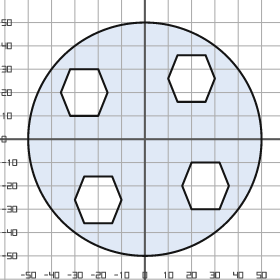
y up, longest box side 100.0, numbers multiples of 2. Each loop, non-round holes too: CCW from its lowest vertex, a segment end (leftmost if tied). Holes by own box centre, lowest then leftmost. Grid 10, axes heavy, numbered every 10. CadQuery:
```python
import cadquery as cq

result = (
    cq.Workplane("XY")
    .moveTo(0.0, 0.0)
    .circle(50.0)
    .moveTo(-26.0, -36.0)
    .lineTo(-14.0, -36.0)
    .lineTo(-10.0, -26.0)
    .lineTo(-14.0, -16.0)
    .lineTo(-26.0, -16.0)
    .lineTo(-30.0, -26.0)
    .close()
    .moveTo(20.0, -30.0)
    .lineTo(32.0, -30.0)
    .lineTo(36.0, -20.0)
    .lineTo(32.0, -10.0)
    .lineTo(20.0, -10.0)
    .lineTo(16.0, -20.0)
    .close()
    .moveTo(-32.0, 10.0)
    .lineTo(-20.0, 10.0)
    .lineTo(-16.0, 20.0)
    .lineTo(-20.0, 30.0)
    .lineTo(-32.0, 30.0)
    .lineTo(-36.0, 20.0)
    .close()
    .moveTo(14.0, 16.0)
    .lineTo(26.0, 16.0)
    .lineTo(30.0, 26.0)
    .lineTo(26.0, 36.0)
    .lineTo(14.0, 36.0)
    .lineTo(10.0, 26.0)
    .close()
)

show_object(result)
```